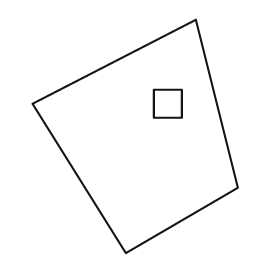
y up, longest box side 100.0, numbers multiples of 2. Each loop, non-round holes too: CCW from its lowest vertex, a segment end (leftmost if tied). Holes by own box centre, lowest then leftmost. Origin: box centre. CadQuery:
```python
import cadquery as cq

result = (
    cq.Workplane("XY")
    .moveTo(-4.0, -50.0)
    .lineTo(44.0, -22.0)
    .lineTo(26.0, 50.0)
    .lineTo(-44.0, 14.0)
    .close()
    .moveTo(8.0, 8.0)
    .lineTo(20.0, 8.0)
    .lineTo(20.0, 20.0)
    .lineTo(8.0, 20.0)
    .close()
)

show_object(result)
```